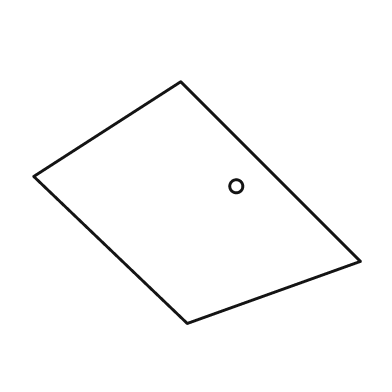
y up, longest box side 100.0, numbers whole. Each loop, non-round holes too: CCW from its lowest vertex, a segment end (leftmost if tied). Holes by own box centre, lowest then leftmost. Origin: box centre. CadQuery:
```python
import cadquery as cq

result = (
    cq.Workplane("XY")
    .moveTo(-3.0, -37.0)
    .lineTo(50.0, -18.0)
    .lineTo(-5.0, 37.0)
    .lineTo(-50.0, 8.0)
    .close()
    .moveTo(12.0, 5.0)
    .circle(2.0)
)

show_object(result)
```